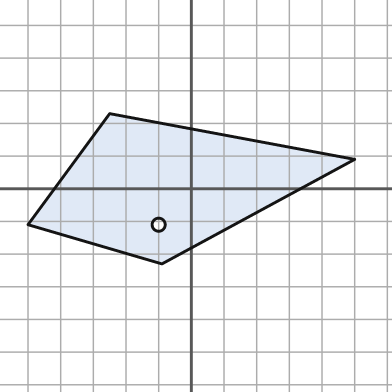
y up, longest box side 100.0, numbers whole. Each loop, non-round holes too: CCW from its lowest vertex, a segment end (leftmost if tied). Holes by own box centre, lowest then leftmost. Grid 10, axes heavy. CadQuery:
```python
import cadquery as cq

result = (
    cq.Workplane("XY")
    .moveTo(-9.0, -23.0)
    .lineTo(50.0, 9.0)
    .lineTo(-25.0, 23.0)
    .lineTo(-50.0, -11.0)
    .close()
    .moveTo(-10.0, -11.0)
    .circle(2.0)
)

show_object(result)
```